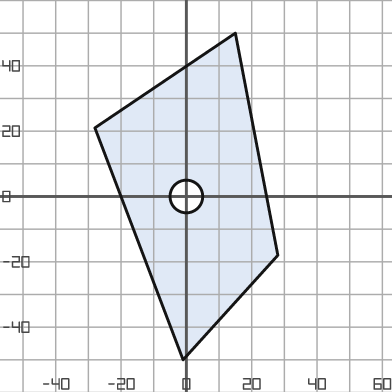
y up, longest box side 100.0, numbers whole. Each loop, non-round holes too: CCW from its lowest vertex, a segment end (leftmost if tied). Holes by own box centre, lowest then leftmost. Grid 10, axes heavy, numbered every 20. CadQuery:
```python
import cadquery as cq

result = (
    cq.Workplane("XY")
    .moveTo(-1.0, -50.0)
    .lineTo(28.0, -18.0)
    .lineTo(15.0, 50.0)
    .lineTo(-28.0, 21.0)
    .close()
    .moveTo(0.0, 0.0)
    .circle(5.0)
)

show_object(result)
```